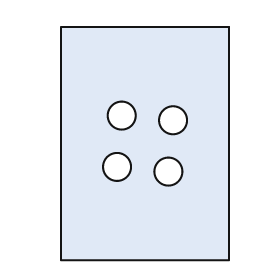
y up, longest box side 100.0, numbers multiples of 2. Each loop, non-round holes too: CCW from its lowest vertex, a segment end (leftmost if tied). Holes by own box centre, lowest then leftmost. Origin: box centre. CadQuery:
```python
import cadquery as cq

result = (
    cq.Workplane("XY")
    .moveTo(-36.0, -50.0)
    .lineTo(36.0, -50.0)
    .lineTo(36.0, 50.0)
    .lineTo(-36.0, 50.0)
    .close()
    .moveTo(10.0, -12.0)
    .circle(6.0)
    .moveTo(-12.0, -10.0)
    .circle(6.0)
    .moveTo(12.0, 10.0)
    .circle(6.0)
    .moveTo(-10.0, 12.0)
    .circle(6.0)
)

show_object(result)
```